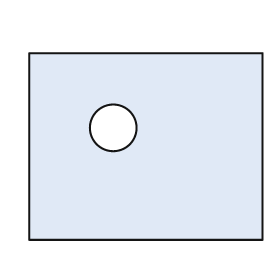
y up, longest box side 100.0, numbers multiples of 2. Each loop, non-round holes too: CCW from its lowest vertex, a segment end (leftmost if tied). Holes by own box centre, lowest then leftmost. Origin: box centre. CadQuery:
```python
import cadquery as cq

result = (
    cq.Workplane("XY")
    .moveTo(-50.0, -40.0)
    .lineTo(50.0, -40.0)
    .lineTo(50.0, 40.0)
    .lineTo(-50.0, 40.0)
    .close()
    .moveTo(-14.0, 8.0)
    .circle(10.0)
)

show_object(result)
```